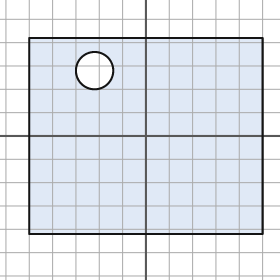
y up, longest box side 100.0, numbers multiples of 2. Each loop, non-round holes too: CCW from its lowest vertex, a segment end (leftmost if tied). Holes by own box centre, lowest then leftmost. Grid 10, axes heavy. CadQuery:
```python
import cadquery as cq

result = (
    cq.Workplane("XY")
    .moveTo(-50.0, -42.0)
    .lineTo(50.0, -42.0)
    .lineTo(50.0, 42.0)
    .lineTo(-50.0, 42.0)
    .close()
    .moveTo(-22.0, 28.0)
    .circle(8.0)
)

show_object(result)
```